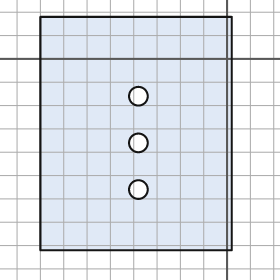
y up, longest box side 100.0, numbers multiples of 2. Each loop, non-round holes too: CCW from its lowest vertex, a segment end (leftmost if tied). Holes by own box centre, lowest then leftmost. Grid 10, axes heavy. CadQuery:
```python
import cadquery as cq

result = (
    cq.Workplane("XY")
    .moveTo(-80.0, -82.0)
    .lineTo(2.0, -82.0)
    .lineTo(2.0, 18.0)
    .lineTo(-80.0, 18.0)
    .close()
    .moveTo(-38.0, -56.0)
    .circle(4.0)
    .moveTo(-38.0, -36.0)
    .circle(4.0)
    .moveTo(-38.0, -16.0)
    .circle(4.0)
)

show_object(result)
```